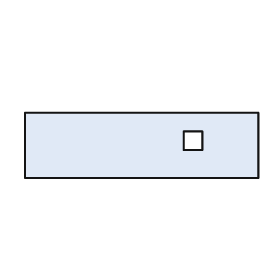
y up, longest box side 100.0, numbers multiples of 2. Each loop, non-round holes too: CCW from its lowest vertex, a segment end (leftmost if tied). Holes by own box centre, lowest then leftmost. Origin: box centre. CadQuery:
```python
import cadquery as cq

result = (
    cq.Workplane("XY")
    .moveTo(-50.0, -14.0)
    .lineTo(50.0, -14.0)
    .lineTo(50.0, 14.0)
    .lineTo(-50.0, 14.0)
    .close()
    .moveTo(18.0, -2.0)
    .lineTo(26.0, -2.0)
    .lineTo(26.0, 6.0)
    .lineTo(18.0, 6.0)
    .close()
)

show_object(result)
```